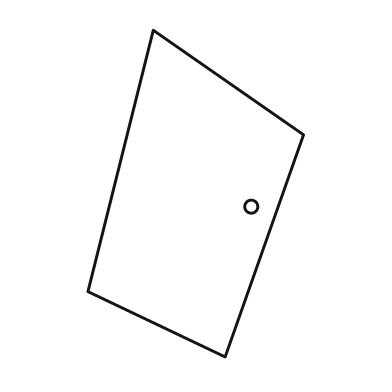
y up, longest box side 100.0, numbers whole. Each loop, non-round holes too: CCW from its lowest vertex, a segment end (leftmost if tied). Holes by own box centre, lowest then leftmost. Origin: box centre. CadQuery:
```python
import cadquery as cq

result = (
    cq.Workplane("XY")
    .moveTo(9.0, -50.0)
    .lineTo(33.0, 18.0)
    .lineTo(-13.0, 50.0)
    .lineTo(-33.0, -30.0)
    .close()
    .moveTo(17.0, -4.0)
    .circle(2.0)
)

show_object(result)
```